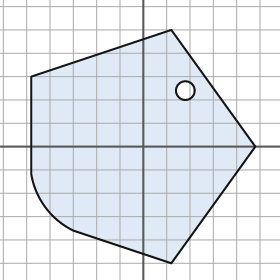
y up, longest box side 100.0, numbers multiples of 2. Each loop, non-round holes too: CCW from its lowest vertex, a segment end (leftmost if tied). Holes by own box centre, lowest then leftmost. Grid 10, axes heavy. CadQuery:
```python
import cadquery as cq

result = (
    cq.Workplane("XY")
    .moveTo(12.0, -50.0)
    .lineTo(48.0, 0.0)
    .lineTo(12.0, 50.0)
    .lineTo(-48.0, 30.0)
    .lineTo(-48.0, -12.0)
    .threePointArc((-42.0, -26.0), (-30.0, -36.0))
    .close()
    .moveTo(18.0, 24.0)
    .circle(4.0)
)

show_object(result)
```